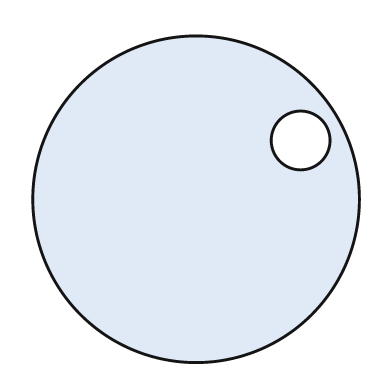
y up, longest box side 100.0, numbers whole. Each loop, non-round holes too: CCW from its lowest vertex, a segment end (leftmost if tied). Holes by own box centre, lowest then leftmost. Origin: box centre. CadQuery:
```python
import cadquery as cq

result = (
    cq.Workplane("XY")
    .moveTo(0.0, 0.0)
    .circle(50.0)
    .moveTo(32.0, 18.0)
    .circle(9.0)
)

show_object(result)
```